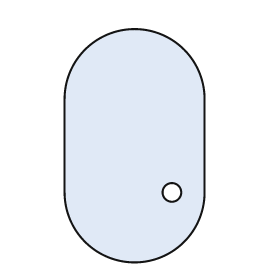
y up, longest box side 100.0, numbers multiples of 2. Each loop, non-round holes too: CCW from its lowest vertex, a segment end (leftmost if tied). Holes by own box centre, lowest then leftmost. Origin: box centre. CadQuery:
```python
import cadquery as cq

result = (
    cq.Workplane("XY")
    .moveTo(-30.0, -20.0)
    .threePointArc((0.0, -50.0), (30.0, -20.0))
    .lineTo(30.0, 20.0)
    .threePointArc((0.0, 50.0), (-30.0, 20.0))
    .close()
    .moveTo(16.0, -20.0)
    .circle(4.0)
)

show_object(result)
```